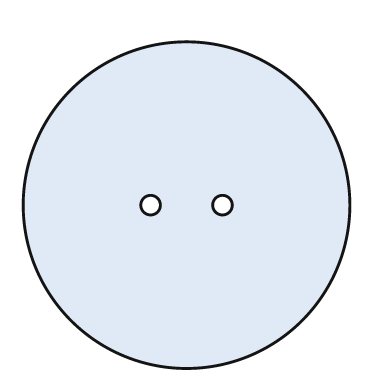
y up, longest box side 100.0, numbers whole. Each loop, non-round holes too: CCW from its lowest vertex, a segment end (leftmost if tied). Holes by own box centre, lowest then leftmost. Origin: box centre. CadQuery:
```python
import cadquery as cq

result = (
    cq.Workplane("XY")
    .moveTo(0.0, 0.0)
    .circle(50.0)
    .moveTo(-11.0, 0.0)
    .circle(3.0)
    .moveTo(11.0, 0.0)
    .circle(3.0)
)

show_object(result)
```